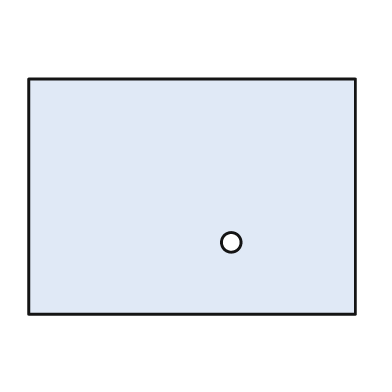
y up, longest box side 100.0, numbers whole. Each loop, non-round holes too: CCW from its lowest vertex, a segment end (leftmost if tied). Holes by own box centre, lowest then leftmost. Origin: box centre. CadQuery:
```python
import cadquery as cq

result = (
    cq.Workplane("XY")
    .moveTo(-50.0, -36.0)
    .lineTo(50.0, -36.0)
    .lineTo(50.0, 36.0)
    .lineTo(-50.0, 36.0)
    .close()
    .moveTo(12.0, -14.0)
    .circle(3.0)
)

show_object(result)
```